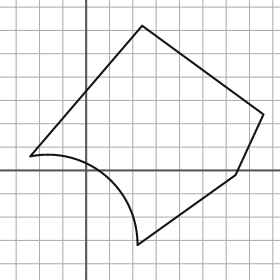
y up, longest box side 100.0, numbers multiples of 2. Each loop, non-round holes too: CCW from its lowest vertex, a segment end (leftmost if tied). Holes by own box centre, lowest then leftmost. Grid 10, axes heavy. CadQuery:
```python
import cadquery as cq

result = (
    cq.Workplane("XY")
    .moveTo(22.0, -32.0)
    .lineTo(64.0, -2.0)
    .lineTo(76.0, 24.0)
    .lineTo(24.0, 62.0)
    .lineTo(-24.0, 6.0)
    .threePointArc((8.0, -2.0), (22.0, -32.0))
    .close()
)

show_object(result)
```